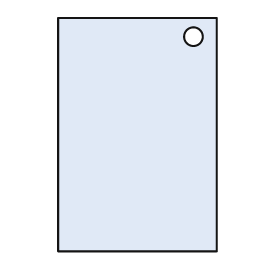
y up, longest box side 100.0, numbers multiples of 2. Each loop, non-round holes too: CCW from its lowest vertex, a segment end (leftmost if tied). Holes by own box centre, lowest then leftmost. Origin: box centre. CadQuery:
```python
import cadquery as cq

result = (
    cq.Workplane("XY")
    .moveTo(-34.0, -50.0)
    .lineTo(34.0, -50.0)
    .lineTo(34.0, 50.0)
    .lineTo(-34.0, 50.0)
    .close()
    .moveTo(24.0, 42.0)
    .circle(4.0)
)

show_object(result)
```